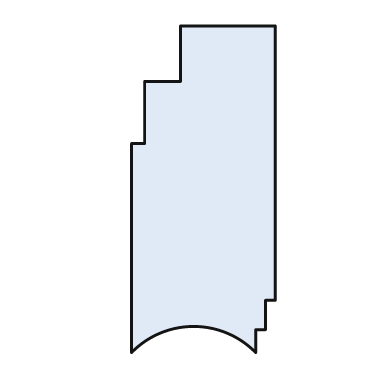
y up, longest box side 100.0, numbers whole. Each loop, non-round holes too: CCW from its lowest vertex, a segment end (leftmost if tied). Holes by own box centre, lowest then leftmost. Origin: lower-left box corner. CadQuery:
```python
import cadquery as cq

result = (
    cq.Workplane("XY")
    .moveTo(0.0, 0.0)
    .threePointArc((19.0, 8.0), (38.0, 0.0))
    .lineTo(38.0, 7.0)
    .lineTo(41.0, 7.0)
    .lineTo(41.0, 16.0)
    .lineTo(44.0, 16.0)
    .lineTo(44.0, 100.0)
    .lineTo(15.0, 100.0)
    .lineTo(15.0, 83.0)
    .lineTo(4.0, 83.0)
    .lineTo(4.0, 64.0)
    .lineTo(0.0, 64.0)
    .close()
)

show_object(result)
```